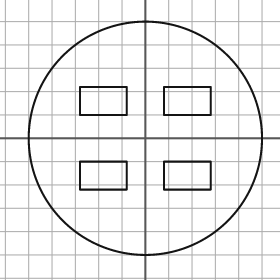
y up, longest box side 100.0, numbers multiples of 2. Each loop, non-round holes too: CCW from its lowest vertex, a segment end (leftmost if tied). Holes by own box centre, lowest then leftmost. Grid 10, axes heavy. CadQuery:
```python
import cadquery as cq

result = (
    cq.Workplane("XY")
    .moveTo(0.0, 0.0)
    .circle(50.0)
    .moveTo(-28.0, -22.0)
    .lineTo(-8.0, -22.0)
    .lineTo(-8.0, -10.0)
    .lineTo(-28.0, -10.0)
    .close()
    .moveTo(8.0, -22.0)
    .lineTo(28.0, -22.0)
    .lineTo(28.0, -10.0)
    .lineTo(8.0, -10.0)
    .close()
    .moveTo(-28.0, 10.0)
    .lineTo(-8.0, 10.0)
    .lineTo(-8.0, 22.0)
    .lineTo(-28.0, 22.0)
    .close()
    .moveTo(8.0, 10.0)
    .lineTo(28.0, 10.0)
    .lineTo(28.0, 22.0)
    .lineTo(8.0, 22.0)
    .close()
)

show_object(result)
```